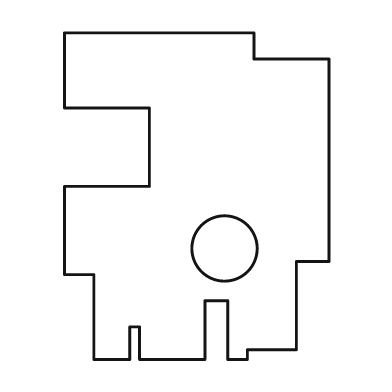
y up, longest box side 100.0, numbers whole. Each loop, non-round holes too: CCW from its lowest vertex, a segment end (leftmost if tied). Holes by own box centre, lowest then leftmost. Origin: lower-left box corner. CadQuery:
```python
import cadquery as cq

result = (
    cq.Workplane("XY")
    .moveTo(9.0, 0.0)
    .lineTo(20.0, 0.0)
    .lineTo(20.0, 10.0)
    .lineTo(23.0, 10.0)
    .lineTo(23.0, 0.0)
    .lineTo(43.0, 0.0)
    .lineTo(43.0, 18.0)
    .lineTo(50.0, 18.0)
    .lineTo(50.0, 0.0)
    .lineTo(56.0, 0.0)
    .lineTo(56.0, 3.0)
    .lineTo(71.0, 3.0)
    .lineTo(71.0, 30.0)
    .lineTo(81.0, 30.0)
    .lineTo(81.0, 92.0)
    .lineTo(58.0, 92.0)
    .lineTo(58.0, 100.0)
    .lineTo(0.0, 100.0)
    .lineTo(0.0, 77.0)
    .lineTo(26.0, 77.0)
    .lineTo(26.0, 53.0)
    .lineTo(0.0, 53.0)
    .lineTo(0.0, 26.0)
    .lineTo(9.0, 26.0)
    .close()
    .moveTo(49.0, 34.0)
    .circle(10.0)
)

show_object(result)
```